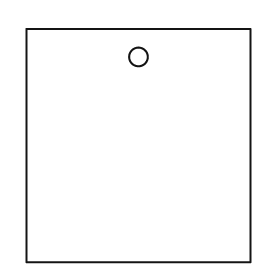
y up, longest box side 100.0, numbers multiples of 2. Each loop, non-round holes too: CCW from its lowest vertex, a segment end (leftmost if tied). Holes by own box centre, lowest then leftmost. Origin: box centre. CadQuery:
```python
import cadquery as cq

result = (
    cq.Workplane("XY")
    .moveTo(-48.0, -50.0)
    .lineTo(48.0, -50.0)
    .lineTo(48.0, 50.0)
    .lineTo(-48.0, 50.0)
    .close()
    .moveTo(0.0, 38.0)
    .circle(4.0)
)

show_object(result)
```